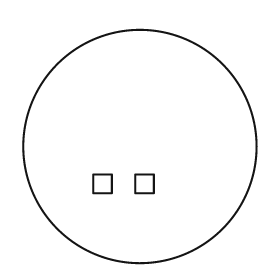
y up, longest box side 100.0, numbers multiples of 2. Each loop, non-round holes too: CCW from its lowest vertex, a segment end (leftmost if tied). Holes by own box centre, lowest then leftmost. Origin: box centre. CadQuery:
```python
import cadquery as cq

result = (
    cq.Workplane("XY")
    .moveTo(0.0, 0.0)
    .circle(50.0)
    .moveTo(-20.0, -20.0)
    .lineTo(-12.0, -20.0)
    .lineTo(-12.0, -12.0)
    .lineTo(-20.0, -12.0)
    .close()
    .moveTo(-2.0, -20.0)
    .lineTo(6.0, -20.0)
    .lineTo(6.0, -12.0)
    .lineTo(-2.0, -12.0)
    .close()
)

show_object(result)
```